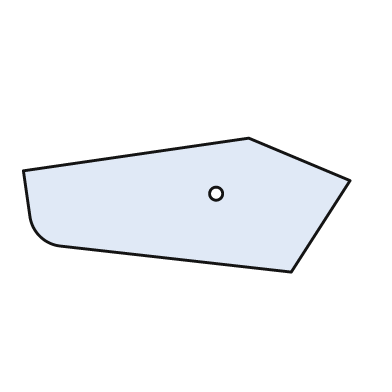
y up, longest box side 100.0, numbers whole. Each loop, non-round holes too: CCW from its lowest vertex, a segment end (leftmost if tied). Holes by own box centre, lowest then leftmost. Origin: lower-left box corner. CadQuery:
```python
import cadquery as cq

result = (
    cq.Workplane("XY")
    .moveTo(82.0, 0.0)
    .lineTo(100.0, 28.0)
    .lineTo(69.0, 41.0)
    .lineTo(0.0, 31.0)
    .lineTo(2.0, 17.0)
    .threePointArc((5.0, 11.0), (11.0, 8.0))
    .close()
    .moveTo(59.0, 24.0)
    .circle(2.0)
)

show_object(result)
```